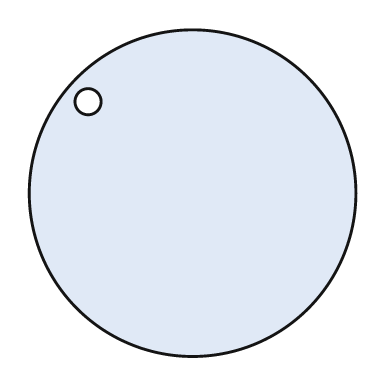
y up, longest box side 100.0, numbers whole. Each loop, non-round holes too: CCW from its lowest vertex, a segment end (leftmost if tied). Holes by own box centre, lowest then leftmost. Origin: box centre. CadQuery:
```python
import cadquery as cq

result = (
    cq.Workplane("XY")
    .moveTo(0.0, 0.0)
    .circle(50.0)
    .moveTo(-32.0, 28.0)
    .circle(4.0)
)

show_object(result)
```